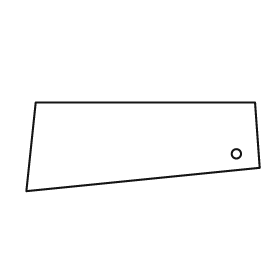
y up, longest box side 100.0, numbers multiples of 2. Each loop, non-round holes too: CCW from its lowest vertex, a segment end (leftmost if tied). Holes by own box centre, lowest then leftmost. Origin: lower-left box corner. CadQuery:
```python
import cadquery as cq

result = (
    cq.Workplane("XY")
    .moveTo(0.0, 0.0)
    .lineTo(100.0, 10.0)
    .lineTo(98.0, 38.0)
    .lineTo(4.0, 38.0)
    .close()
    .moveTo(90.0, 16.0)
    .circle(2.0)
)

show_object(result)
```